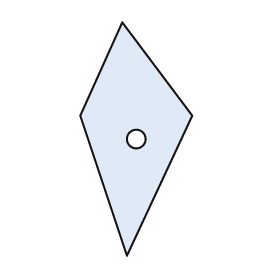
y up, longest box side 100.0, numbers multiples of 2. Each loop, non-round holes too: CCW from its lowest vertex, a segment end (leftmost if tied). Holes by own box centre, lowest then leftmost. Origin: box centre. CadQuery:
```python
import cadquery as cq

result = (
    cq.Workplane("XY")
    .moveTo(-4.0, -50.0)
    .lineTo(24.0, 10.0)
    .lineTo(-6.0, 50.0)
    .lineTo(-24.0, 10.0)
    .close()
    .moveTo(0.0, 0.0)
    .circle(4.0)
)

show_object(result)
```